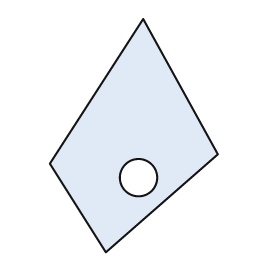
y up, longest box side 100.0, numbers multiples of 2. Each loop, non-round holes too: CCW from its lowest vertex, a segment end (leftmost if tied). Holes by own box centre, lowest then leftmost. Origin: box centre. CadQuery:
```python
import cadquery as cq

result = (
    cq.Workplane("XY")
    .moveTo(-12.0, -50.0)
    .lineTo(36.0, -8.0)
    .lineTo(4.0, 50.0)
    .lineTo(-36.0, -12.0)
    .close()
    .moveTo(2.0, -18.0)
    .circle(8.0)
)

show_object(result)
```